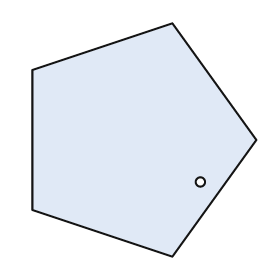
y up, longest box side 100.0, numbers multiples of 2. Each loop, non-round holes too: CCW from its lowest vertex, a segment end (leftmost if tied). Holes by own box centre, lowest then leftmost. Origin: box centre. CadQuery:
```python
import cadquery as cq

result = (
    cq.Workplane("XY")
    .moveTo(12.0, -50.0)
    .lineTo(48.0, 0.0)
    .lineTo(12.0, 50.0)
    .lineTo(-48.0, 30.0)
    .lineTo(-48.0, -30.0)
    .close()
    .moveTo(24.0, -18.0)
    .circle(2.0)
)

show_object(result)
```